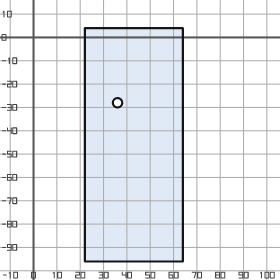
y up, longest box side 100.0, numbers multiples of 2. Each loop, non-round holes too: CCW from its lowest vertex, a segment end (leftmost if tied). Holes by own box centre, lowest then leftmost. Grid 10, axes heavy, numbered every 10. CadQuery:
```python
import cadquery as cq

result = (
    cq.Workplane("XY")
    .moveTo(22.0, -96.0)
    .lineTo(64.0, -96.0)
    .lineTo(64.0, 4.0)
    .lineTo(22.0, 4.0)
    .close()
    .moveTo(36.0, -28.0)
    .circle(2.0)
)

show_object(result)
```